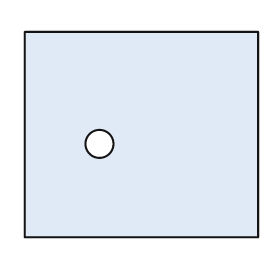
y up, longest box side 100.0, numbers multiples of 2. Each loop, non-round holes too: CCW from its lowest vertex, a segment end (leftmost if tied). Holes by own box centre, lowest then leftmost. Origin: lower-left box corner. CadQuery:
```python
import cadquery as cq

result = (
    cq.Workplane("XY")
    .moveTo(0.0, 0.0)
    .lineTo(100.0, 0.0)
    .lineTo(100.0, 88.0)
    .lineTo(0.0, 88.0)
    .close()
    .moveTo(32.0, 40.0)
    .circle(6.0)
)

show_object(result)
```